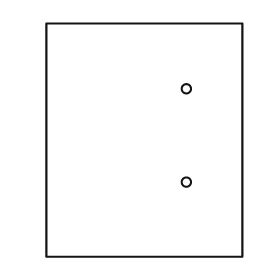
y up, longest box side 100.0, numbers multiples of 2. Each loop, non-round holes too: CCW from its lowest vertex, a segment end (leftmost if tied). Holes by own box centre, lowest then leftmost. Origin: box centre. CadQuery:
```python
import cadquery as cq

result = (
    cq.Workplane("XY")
    .moveTo(-42.0, -50.0)
    .lineTo(42.0, -50.0)
    .lineTo(42.0, 50.0)
    .lineTo(-42.0, 50.0)
    .close()
    .moveTo(18.0, -18.0)
    .circle(2.0)
    .moveTo(18.0, 22.0)
    .circle(2.0)
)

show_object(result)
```